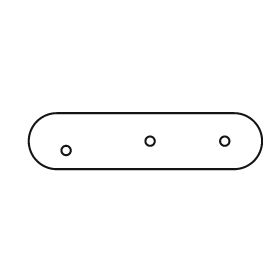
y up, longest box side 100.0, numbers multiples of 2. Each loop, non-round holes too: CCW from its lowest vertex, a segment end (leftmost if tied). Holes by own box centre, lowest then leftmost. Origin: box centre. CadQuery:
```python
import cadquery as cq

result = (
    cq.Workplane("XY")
    .moveTo(-38.0, -12.0)
    .lineTo(38.0, -12.0)
    .threePointArc((50.0, 0.0), (38.0, 12.0))
    .lineTo(-38.0, 12.0)
    .threePointArc((-50.0, 0.0), (-38.0, -12.0))
    .close()
    .moveTo(-34.0, -4.0)
    .circle(2.0)
    .moveTo(2.0, 0.0)
    .circle(2.0)
    .moveTo(34.0, 0.0)
    .circle(2.0)
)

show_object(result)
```